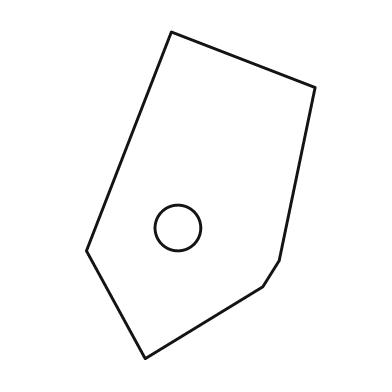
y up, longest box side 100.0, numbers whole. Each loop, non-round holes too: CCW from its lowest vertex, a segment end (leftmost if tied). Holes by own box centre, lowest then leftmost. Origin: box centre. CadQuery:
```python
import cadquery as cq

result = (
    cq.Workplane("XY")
    .moveTo(-17.0, -50.0)
    .lineTo(19.0, -28.0)
    .lineTo(24.0, -20.0)
    .lineTo(35.0, 33.0)
    .lineTo(-9.0, 50.0)
    .lineTo(-35.0, -17.0)
    .close()
    .moveTo(-7.0, -10.0)
    .circle(7.0)
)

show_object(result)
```